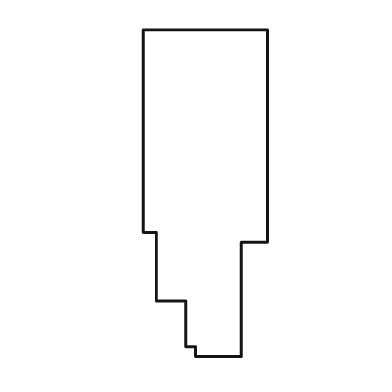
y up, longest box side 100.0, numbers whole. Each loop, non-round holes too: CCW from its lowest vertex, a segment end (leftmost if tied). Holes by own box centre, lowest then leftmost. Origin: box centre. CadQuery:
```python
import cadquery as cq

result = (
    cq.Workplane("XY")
    .moveTo(-3.0, -50.0)
    .lineTo(11.0, -50.0)
    .lineTo(11.0, -15.0)
    .lineTo(19.0, -15.0)
    .lineTo(19.0, 50.0)
    .lineTo(-19.0, 50.0)
    .lineTo(-19.0, -12.0)
    .lineTo(-15.0, -12.0)
    .lineTo(-15.0, -33.0)
    .lineTo(-6.0, -33.0)
    .lineTo(-6.0, -47.0)
    .lineTo(-3.0, -47.0)
    .close()
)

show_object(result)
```